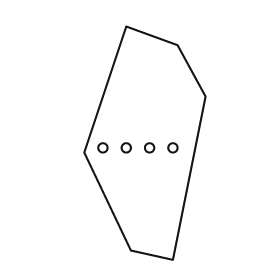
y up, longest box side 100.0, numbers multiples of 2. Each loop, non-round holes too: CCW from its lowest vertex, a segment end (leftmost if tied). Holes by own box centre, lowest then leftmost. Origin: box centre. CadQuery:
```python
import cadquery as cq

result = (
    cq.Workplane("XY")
    .moveTo(12.0, -50.0)
    .lineTo(26.0, 20.0)
    .lineTo(14.0, 42.0)
    .lineTo(-8.0, 50.0)
    .lineTo(-26.0, -4.0)
    .lineTo(-6.0, -46.0)
    .close()
    .moveTo(-18.0, -2.0)
    .circle(2.0)
    .moveTo(-8.0, -2.0)
    .circle(2.0)
    .moveTo(2.0, -2.0)
    .circle(2.0)
    .moveTo(12.0, -2.0)
    .circle(2.0)
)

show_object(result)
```